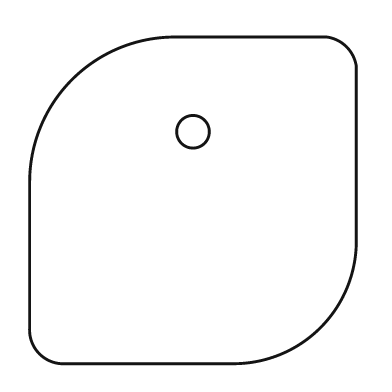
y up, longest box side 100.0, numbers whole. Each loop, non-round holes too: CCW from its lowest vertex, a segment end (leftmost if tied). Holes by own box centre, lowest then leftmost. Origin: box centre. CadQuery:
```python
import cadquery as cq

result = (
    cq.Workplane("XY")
    .moveTo(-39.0, -50.0)
    .lineTo(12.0, -50.0)
    .threePointArc((39.0, -39.0), (50.0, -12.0))
    .lineTo(50.0, 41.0)
    .threePointArc((47.0, 47.0), (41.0, 50.0))
    .lineTo(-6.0, 50.0)
    .threePointArc((-37.0, 37.0), (-50.0, 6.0))
    .lineTo(-50.0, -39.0)
    .threePointArc((-47.0, -47.0), (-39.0, -50.0))
    .close()
    .moveTo(0.0, 21.0)
    .circle(5.0)
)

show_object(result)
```